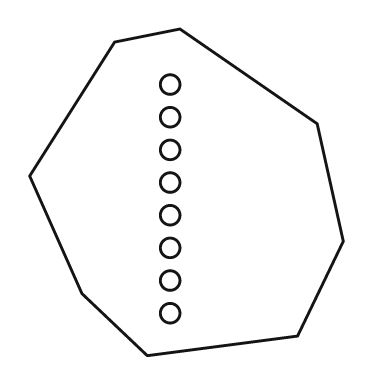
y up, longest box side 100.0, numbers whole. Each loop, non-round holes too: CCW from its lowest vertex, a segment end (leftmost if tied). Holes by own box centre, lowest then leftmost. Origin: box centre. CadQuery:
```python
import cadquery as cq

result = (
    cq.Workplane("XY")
    .moveTo(-12.0, -50.0)
    .lineTo(34.0, -44.0)
    .lineTo(48.0, -15.0)
    .lineTo(40.0, 21.0)
    .lineTo(-2.0, 50.0)
    .lineTo(-22.0, 46.0)
    .lineTo(-48.0, 5.0)
    .lineTo(-32.0, -31.0)
    .close()
    .moveTo(-5.0, -37.0)
    .circle(3.0)
    .moveTo(-5.0, -27.0)
    .circle(3.0)
    .moveTo(-5.0, -17.0)
    .circle(3.0)
    .moveTo(-5.0, -7.0)
    .circle(3.0)
    .moveTo(-5.0, 3.0)
    .circle(3.0)
    .moveTo(-5.0, 13.0)
    .circle(3.0)
    .moveTo(-5.0, 23.0)
    .circle(3.0)
    .moveTo(-5.0, 33.0)
    .circle(3.0)
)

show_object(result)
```